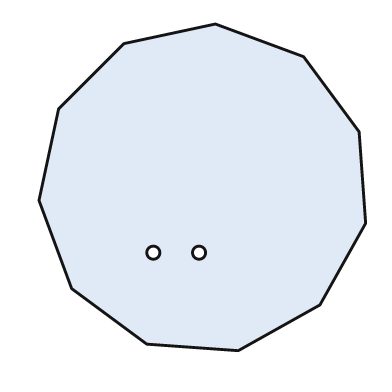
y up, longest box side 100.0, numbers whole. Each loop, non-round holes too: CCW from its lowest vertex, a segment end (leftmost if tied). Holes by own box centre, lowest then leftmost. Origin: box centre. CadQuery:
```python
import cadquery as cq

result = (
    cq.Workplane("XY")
    .moveTo(11.0, -50.0)
    .lineTo(36.0, -36.0)
    .lineTo(50.0, -11.0)
    .lineTo(48.0, 17.0)
    .lineTo(31.0, 40.0)
    .lineTo(4.0, 50.0)
    .lineTo(-24.0, 44.0)
    .lineTo(-44.0, 24.0)
    .lineTo(-50.0, -4.0)
    .lineTo(-40.0, -31.0)
    .lineTo(-17.0, -48.0)
    .close()
    .moveTo(-15.0, -20.0)
    .circle(2.0)
    .moveTo(-1.0, -20.0)
    .circle(2.0)
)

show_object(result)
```